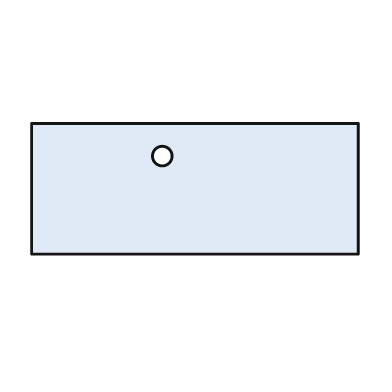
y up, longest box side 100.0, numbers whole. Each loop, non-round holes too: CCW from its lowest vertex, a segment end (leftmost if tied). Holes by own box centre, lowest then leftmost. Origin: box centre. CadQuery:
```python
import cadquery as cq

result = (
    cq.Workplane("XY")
    .moveTo(-50.0, -20.0)
    .lineTo(50.0, -20.0)
    .lineTo(50.0, 20.0)
    .lineTo(-50.0, 20.0)
    .close()
    .moveTo(-10.0, 10.0)
    .circle(3.0)
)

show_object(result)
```